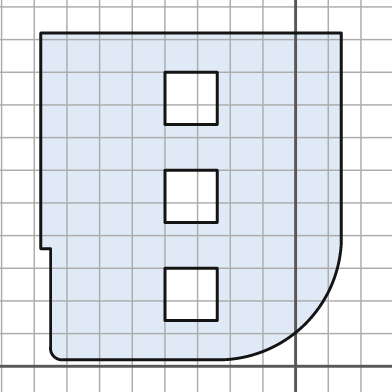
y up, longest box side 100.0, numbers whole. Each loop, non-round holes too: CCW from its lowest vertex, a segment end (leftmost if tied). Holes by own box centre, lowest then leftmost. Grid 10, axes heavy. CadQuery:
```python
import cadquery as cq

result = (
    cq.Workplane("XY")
    .moveTo(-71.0, 2.0)
    .lineTo(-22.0, 2.0)
    .threePointArc((3.0, 13.0), (14.0, 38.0))
    .lineTo(14.0, 102.0)
    .lineTo(-78.0, 102.0)
    .lineTo(-78.0, 36.0)
    .lineTo(-75.0, 36.0)
    .lineTo(-75.0, 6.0)
    .threePointArc((-74.0, 3.0), (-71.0, 2.0))
    .close()
    .moveTo(-40.0, 14.0)
    .lineTo(-24.0, 14.0)
    .lineTo(-24.0, 30.0)
    .lineTo(-40.0, 30.0)
    .close()
    .moveTo(-40.0, 44.0)
    .lineTo(-24.0, 44.0)
    .lineTo(-24.0, 60.0)
    .lineTo(-40.0, 60.0)
    .close()
    .moveTo(-40.0, 74.0)
    .lineTo(-24.0, 74.0)
    .lineTo(-24.0, 90.0)
    .lineTo(-40.0, 90.0)
    .close()
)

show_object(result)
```